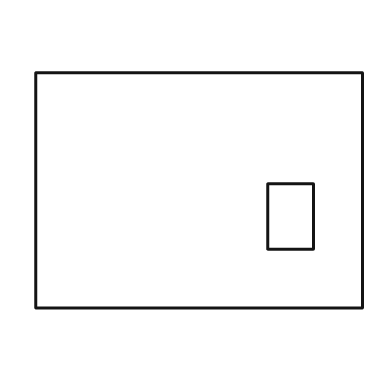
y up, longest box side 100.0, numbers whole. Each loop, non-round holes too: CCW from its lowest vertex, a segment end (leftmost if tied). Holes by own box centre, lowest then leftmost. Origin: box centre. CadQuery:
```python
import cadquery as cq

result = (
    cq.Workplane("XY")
    .moveTo(-50.0, -36.0)
    .lineTo(50.0, -36.0)
    .lineTo(50.0, 36.0)
    .lineTo(-50.0, 36.0)
    .close()
    .moveTo(21.0, -18.0)
    .lineTo(35.0, -18.0)
    .lineTo(35.0, 2.0)
    .lineTo(21.0, 2.0)
    .close()
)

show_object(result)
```